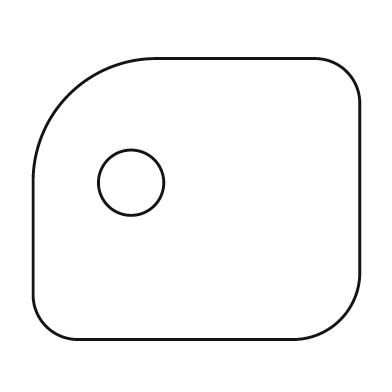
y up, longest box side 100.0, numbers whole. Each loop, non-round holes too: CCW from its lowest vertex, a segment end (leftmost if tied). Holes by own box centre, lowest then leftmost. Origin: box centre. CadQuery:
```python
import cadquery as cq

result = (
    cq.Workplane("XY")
    .moveTo(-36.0, -43.0)
    .lineTo(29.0, -43.0)
    .threePointArc((44.0, -37.0), (50.0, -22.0))
    .lineTo(50.0, 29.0)
    .threePointArc((46.0, 39.0), (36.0, 43.0))
    .lineTo(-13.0, 43.0)
    .threePointArc((-39.0, 32.0), (-50.0, 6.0))
    .lineTo(-50.0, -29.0)
    .threePointArc((-46.0, -39.0), (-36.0, -43.0))
    .close()
    .moveTo(-20.0, 5.0)
    .circle(10.0)
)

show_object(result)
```